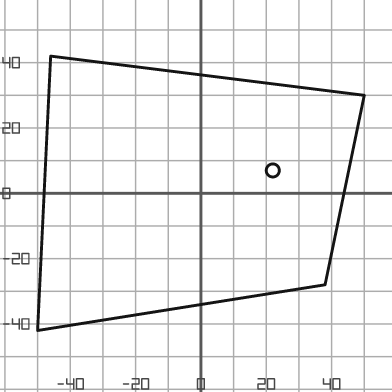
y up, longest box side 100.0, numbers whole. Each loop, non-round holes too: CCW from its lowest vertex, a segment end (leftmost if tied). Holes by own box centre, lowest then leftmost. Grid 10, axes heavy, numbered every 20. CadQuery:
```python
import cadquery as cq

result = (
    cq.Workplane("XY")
    .moveTo(-50.0, -42.0)
    .lineTo(38.0, -28.0)
    .lineTo(50.0, 30.0)
    .lineTo(-46.0, 42.0)
    .close()
    .moveTo(22.0, 7.0)
    .circle(2.0)
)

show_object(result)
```